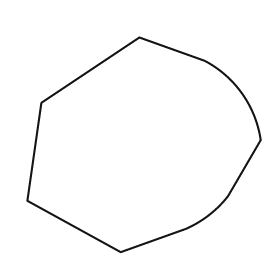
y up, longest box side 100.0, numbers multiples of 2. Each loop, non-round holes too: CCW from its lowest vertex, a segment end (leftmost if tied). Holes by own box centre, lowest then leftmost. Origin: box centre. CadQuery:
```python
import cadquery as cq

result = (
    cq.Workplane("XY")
    .moveTo(-10.0, -46.0)
    .lineTo(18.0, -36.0)
    .threePointArc((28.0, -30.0), (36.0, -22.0))
    .lineTo(50.0, 2.0)
    .threePointArc((42.0, 22.0), (26.0, 36.0))
    .lineTo(-2.0, 46.0)
    .lineTo(-44.0, 18.0)
    .lineTo(-50.0, -24.0)
    .close()
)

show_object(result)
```